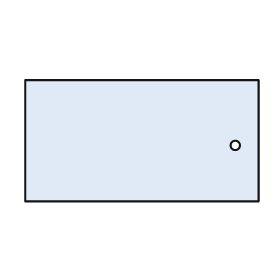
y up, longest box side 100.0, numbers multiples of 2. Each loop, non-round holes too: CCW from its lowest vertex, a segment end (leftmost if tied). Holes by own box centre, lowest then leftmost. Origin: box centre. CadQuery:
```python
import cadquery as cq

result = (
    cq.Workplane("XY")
    .moveTo(-50.0, -26.0)
    .lineTo(50.0, -26.0)
    .lineTo(50.0, 26.0)
    .lineTo(-50.0, 26.0)
    .close()
    .moveTo(40.0, -2.0)
    .circle(2.0)
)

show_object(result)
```